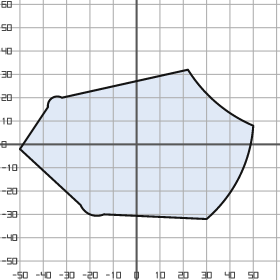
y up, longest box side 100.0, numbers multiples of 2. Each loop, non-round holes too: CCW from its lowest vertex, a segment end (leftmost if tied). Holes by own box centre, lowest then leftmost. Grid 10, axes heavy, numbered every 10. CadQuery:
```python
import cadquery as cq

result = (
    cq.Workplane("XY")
    .moveTo(30.0, -32.0)
    .threePointArc((44.0, -14.0), (50.0, 8.0))
    .threePointArc((34.0, 18.0), (22.0, 32.0))
    .lineTo(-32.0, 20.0)
    .threePointArc((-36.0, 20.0), (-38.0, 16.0))
    .lineTo(-50.0, -2.0)
    .lineTo(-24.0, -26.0)
    .threePointArc((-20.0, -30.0), (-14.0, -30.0))
    .close()
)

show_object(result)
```